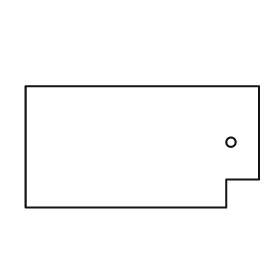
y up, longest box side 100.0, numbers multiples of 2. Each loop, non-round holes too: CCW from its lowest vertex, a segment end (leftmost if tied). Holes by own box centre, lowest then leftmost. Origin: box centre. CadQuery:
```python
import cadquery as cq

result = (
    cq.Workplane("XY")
    .moveTo(-50.0, -26.0)
    .lineTo(36.0, -26.0)
    .lineTo(36.0, -14.0)
    .lineTo(50.0, -14.0)
    .lineTo(50.0, 26.0)
    .lineTo(-50.0, 26.0)
    .close()
    .moveTo(38.0, 2.0)
    .circle(2.0)
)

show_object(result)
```